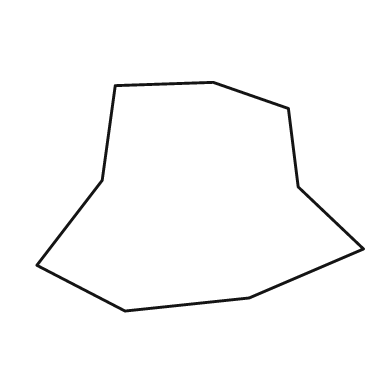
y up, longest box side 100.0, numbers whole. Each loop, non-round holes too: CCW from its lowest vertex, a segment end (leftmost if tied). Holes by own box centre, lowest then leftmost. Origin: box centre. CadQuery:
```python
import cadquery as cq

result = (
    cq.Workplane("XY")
    .moveTo(-23.0, -35.0)
    .lineTo(15.0, -31.0)
    .lineTo(50.0, -16.0)
    .lineTo(30.0, 3.0)
    .lineTo(27.0, 27.0)
    .lineTo(4.0, 35.0)
    .lineTo(-26.0, 34.0)
    .lineTo(-30.0, 5.0)
    .lineTo(-50.0, -21.0)
    .close()
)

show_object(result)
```